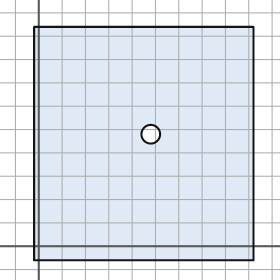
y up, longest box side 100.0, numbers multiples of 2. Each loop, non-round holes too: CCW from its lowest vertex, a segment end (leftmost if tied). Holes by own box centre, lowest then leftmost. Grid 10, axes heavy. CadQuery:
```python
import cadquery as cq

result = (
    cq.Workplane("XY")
    .moveTo(-2.0, -6.0)
    .lineTo(92.0, -6.0)
    .lineTo(92.0, 94.0)
    .lineTo(-2.0, 94.0)
    .close()
    .moveTo(48.0, 48.0)
    .circle(4.0)
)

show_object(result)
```